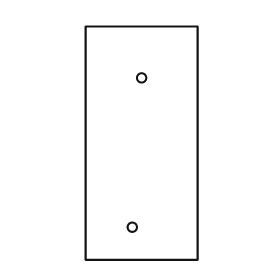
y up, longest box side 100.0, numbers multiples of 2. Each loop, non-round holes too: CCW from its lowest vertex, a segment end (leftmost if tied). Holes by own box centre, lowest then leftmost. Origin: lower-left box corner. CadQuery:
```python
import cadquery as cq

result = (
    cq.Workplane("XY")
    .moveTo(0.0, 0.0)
    .lineTo(48.0, 0.0)
    .lineTo(48.0, 100.0)
    .lineTo(0.0, 100.0)
    .close()
    .moveTo(20.0, 14.0)
    .circle(2.0)
    .moveTo(24.0, 78.0)
    .circle(2.0)
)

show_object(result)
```